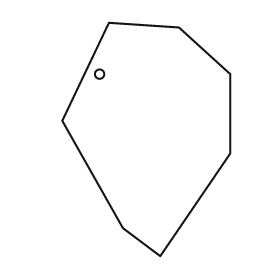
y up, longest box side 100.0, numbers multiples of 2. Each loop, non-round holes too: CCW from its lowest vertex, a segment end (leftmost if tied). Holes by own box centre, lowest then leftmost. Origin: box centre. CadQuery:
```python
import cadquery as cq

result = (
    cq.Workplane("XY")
    .moveTo(6.0, -50.0)
    .lineTo(36.0, -6.0)
    .lineTo(36.0, 28.0)
    .lineTo(14.0, 48.0)
    .lineTo(-16.0, 50.0)
    .lineTo(-36.0, 8.0)
    .lineTo(-10.0, -38.0)
    .close()
    .moveTo(-20.0, 28.0)
    .circle(2.0)
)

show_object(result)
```